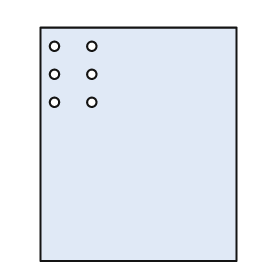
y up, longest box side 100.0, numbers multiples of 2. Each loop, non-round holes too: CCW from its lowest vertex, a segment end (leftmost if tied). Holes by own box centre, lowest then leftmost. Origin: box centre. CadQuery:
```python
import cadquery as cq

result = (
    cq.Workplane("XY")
    .moveTo(-42.0, -50.0)
    .lineTo(42.0, -50.0)
    .lineTo(42.0, 50.0)
    .lineTo(-42.0, 50.0)
    .close()
    .moveTo(-36.0, 18.0)
    .circle(2.0)
    .moveTo(-20.0, 18.0)
    .circle(2.0)
    .moveTo(-36.0, 30.0)
    .circle(2.0)
    .moveTo(-20.0, 30.0)
    .circle(2.0)
    .moveTo(-36.0, 42.0)
    .circle(2.0)
    .moveTo(-20.0, 42.0)
    .circle(2.0)
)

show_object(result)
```